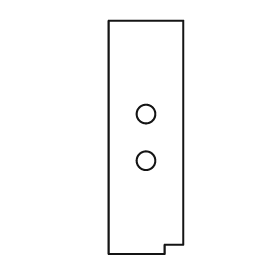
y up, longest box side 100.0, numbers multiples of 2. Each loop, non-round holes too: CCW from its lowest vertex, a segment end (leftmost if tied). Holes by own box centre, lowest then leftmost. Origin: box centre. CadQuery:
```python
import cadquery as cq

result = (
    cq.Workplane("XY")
    .moveTo(-16.0, -50.0)
    .lineTo(8.0, -50.0)
    .lineTo(8.0, -46.0)
    .lineTo(16.0, -46.0)
    .lineTo(16.0, 50.0)
    .lineTo(-16.0, 50.0)
    .close()
    .moveTo(0.0, -10.0)
    .circle(4.0)
    .moveTo(0.0, 10.0)
    .circle(4.0)
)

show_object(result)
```